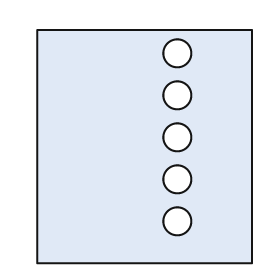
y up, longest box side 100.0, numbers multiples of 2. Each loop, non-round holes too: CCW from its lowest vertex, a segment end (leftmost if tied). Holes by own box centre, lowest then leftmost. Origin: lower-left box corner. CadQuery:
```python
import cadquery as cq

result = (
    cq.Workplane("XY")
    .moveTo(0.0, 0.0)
    .lineTo(92.0, 0.0)
    .lineTo(92.0, 100.0)
    .lineTo(0.0, 100.0)
    .close()
    .moveTo(60.0, 18.0)
    .circle(6.0)
    .moveTo(60.0, 36.0)
    .circle(6.0)
    .moveTo(60.0, 54.0)
    .circle(6.0)
    .moveTo(60.0, 72.0)
    .circle(6.0)
    .moveTo(60.0, 90.0)
    .circle(6.0)
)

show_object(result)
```